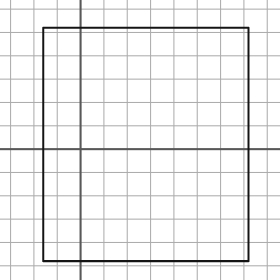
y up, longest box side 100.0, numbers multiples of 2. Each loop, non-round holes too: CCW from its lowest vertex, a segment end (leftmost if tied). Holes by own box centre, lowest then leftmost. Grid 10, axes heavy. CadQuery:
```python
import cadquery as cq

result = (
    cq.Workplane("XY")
    .moveTo(-16.0, -48.0)
    .lineTo(72.0, -48.0)
    .lineTo(72.0, 52.0)
    .lineTo(-16.0, 52.0)
    .close()
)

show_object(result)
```